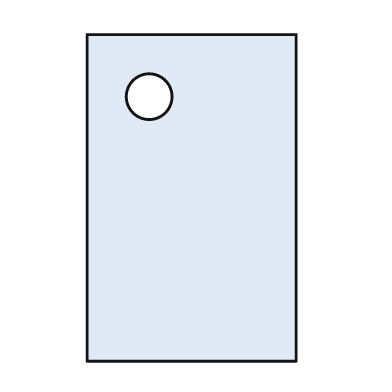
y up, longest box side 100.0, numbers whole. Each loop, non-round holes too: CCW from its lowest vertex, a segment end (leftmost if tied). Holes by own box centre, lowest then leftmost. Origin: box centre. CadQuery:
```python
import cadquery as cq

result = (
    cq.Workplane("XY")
    .moveTo(-32.0, -50.0)
    .lineTo(32.0, -50.0)
    .lineTo(32.0, 50.0)
    .lineTo(-32.0, 50.0)
    .close()
    .moveTo(-13.0, 31.0)
    .circle(7.0)
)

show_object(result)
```